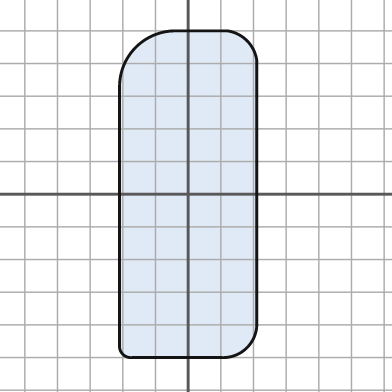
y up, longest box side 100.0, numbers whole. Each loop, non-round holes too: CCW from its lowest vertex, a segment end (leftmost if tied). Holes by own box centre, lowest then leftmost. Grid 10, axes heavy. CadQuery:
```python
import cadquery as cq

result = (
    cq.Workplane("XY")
    .moveTo(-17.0, -50.0)
    .lineTo(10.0, -50.0)
    .threePointArc((18.0, -47.0), (21.0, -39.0))
    .lineTo(21.0, 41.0)
    .threePointArc((18.0, 47.0), (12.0, 50.0))
    .lineTo(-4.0, 50.0)
    .threePointArc((-16.0, 45.0), (-21.0, 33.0))
    .lineTo(-21.0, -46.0)
    .threePointArc((-20.0, -49.0), (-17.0, -50.0))
    .close()
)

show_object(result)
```